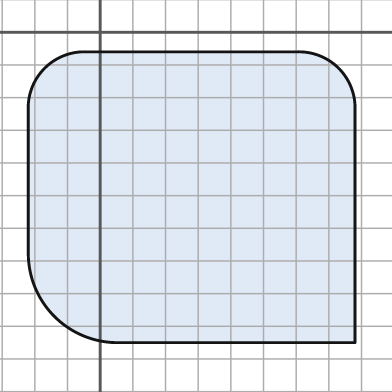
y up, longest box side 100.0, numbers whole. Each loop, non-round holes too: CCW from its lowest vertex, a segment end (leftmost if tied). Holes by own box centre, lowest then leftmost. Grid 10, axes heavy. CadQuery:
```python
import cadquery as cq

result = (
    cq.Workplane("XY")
    .moveTo(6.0, -95.0)
    .lineTo(78.0, -95.0)
    .lineTo(78.0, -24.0)
    .threePointArc((73.0, -11.0), (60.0, -6.0))
    .lineTo(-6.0, -6.0)
    .threePointArc((-17.0, -11.0), (-22.0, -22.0))
    .lineTo(-22.0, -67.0)
    .threePointArc((-14.0, -87.0), (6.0, -95.0))
    .close()
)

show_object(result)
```